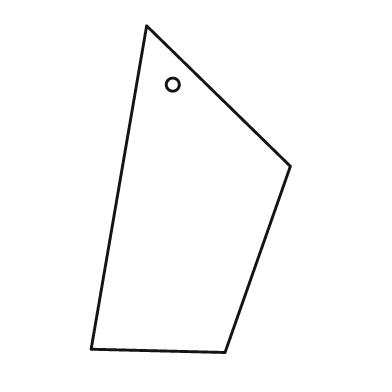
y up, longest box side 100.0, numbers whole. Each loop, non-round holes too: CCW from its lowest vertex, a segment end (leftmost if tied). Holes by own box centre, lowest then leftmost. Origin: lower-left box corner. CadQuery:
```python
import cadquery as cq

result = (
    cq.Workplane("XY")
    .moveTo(41.0, 0.0)
    .lineTo(61.0, 57.0)
    .lineTo(17.0, 100.0)
    .lineTo(0.0, 1.0)
    .close()
    .moveTo(25.0, 82.0)
    .circle(2.0)
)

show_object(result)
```